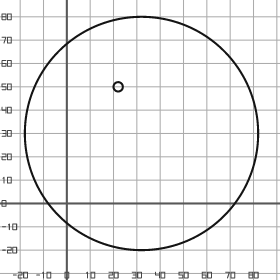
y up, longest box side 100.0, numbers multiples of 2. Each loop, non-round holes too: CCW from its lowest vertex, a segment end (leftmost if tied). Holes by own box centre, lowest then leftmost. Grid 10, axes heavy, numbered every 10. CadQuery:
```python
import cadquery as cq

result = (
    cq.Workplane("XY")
    .moveTo(32.0, 30.0)
    .circle(50.0)
    .moveTo(22.0, 50.0)
    .circle(2.0)
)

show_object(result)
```